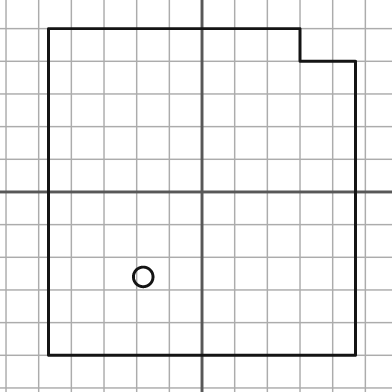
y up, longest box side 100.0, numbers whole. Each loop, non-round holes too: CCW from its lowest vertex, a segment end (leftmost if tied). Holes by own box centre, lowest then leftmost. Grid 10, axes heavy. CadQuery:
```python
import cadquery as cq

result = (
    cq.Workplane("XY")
    .moveTo(-47.0, -50.0)
    .lineTo(47.0, -50.0)
    .lineTo(47.0, 40.0)
    .lineTo(30.0, 40.0)
    .lineTo(30.0, 50.0)
    .lineTo(-47.0, 50.0)
    .close()
    .moveTo(-18.0, -26.0)
    .circle(3.0)
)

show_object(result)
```